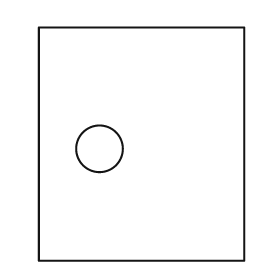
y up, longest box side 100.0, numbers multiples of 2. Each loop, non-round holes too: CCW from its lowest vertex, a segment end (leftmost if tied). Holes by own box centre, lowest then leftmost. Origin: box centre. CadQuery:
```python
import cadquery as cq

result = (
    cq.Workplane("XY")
    .moveTo(-44.0, -50.0)
    .lineTo(44.0, -50.0)
    .lineTo(44.0, 50.0)
    .lineTo(-44.0, 50.0)
    .close()
    .moveTo(-18.0, -2.0)
    .circle(10.0)
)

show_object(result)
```